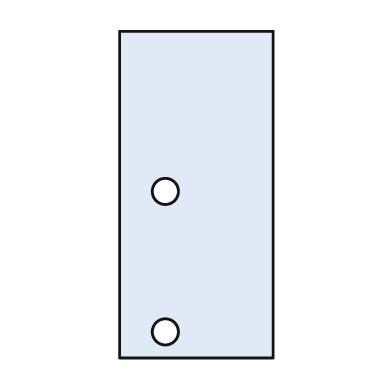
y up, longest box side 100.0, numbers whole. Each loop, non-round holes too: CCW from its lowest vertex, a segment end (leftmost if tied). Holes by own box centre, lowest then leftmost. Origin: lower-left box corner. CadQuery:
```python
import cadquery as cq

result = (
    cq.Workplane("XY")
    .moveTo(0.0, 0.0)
    .lineTo(47.0, 0.0)
    .lineTo(47.0, 100.0)
    .lineTo(0.0, 100.0)
    .close()
    .moveTo(14.0, 8.0)
    .circle(4.0)
    .moveTo(14.0, 51.0)
    .circle(4.0)
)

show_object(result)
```